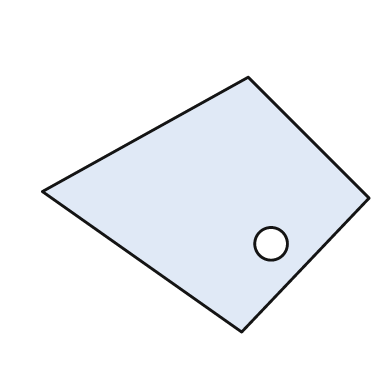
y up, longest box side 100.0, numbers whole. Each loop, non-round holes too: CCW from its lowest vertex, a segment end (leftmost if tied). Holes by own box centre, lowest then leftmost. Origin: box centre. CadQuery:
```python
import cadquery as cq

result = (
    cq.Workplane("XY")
    .moveTo(11.0, -39.0)
    .lineTo(50.0, 2.0)
    .lineTo(13.0, 39.0)
    .lineTo(-50.0, 4.0)
    .close()
    .moveTo(20.0, -12.0)
    .circle(5.0)
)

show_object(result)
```